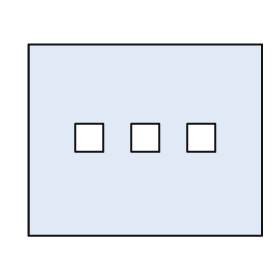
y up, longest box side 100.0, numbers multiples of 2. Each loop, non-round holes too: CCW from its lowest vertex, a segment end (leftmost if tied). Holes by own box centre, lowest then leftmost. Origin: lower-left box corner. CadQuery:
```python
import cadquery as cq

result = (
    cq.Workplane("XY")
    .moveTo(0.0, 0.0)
    .lineTo(100.0, 0.0)
    .lineTo(100.0, 82.0)
    .lineTo(0.0, 82.0)
    .close()
    .moveTo(20.0, 36.0)
    .lineTo(32.0, 36.0)
    .lineTo(32.0, 48.0)
    .lineTo(20.0, 48.0)
    .close()
    .moveTo(44.0, 36.0)
    .lineTo(56.0, 36.0)
    .lineTo(56.0, 48.0)
    .lineTo(44.0, 48.0)
    .close()
    .moveTo(68.0, 36.0)
    .lineTo(80.0, 36.0)
    .lineTo(80.0, 48.0)
    .lineTo(68.0, 48.0)
    .close()
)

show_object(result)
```